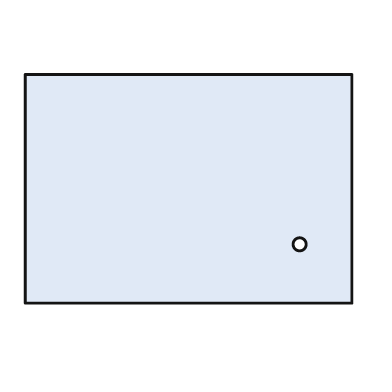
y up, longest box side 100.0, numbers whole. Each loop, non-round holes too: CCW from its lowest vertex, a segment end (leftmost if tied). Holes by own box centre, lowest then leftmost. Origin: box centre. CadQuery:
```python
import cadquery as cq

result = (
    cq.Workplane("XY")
    .moveTo(-50.0, -35.0)
    .lineTo(50.0, -35.0)
    .lineTo(50.0, 35.0)
    .lineTo(-50.0, 35.0)
    .close()
    .moveTo(34.0, -17.0)
    .circle(2.0)
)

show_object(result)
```